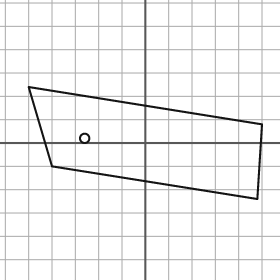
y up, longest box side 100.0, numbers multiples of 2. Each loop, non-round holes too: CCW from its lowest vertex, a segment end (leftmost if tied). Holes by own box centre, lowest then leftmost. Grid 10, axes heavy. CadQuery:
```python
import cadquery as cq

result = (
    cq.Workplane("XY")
    .moveTo(48.0, -24.0)
    .lineTo(50.0, 8.0)
    .lineTo(-50.0, 24.0)
    .lineTo(-40.0, -10.0)
    .close()
    .moveTo(-26.0, 2.0)
    .circle(2.0)
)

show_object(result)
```